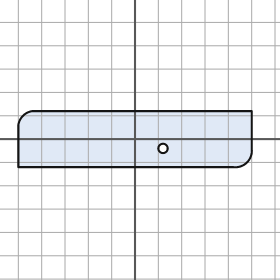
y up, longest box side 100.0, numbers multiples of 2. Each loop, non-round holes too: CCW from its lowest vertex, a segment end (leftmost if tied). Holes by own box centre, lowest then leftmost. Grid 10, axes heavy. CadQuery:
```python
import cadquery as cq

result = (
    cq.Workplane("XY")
    .moveTo(-50.0, -12.0)
    .lineTo(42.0, -12.0)
    .threePointArc((48.0, -10.0), (50.0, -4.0))
    .lineTo(50.0, 12.0)
    .lineTo(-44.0, 12.0)
    .threePointArc((-48.0, 10.0), (-50.0, 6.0))
    .close()
    .moveTo(12.0, -4.0)
    .circle(2.0)
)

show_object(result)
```